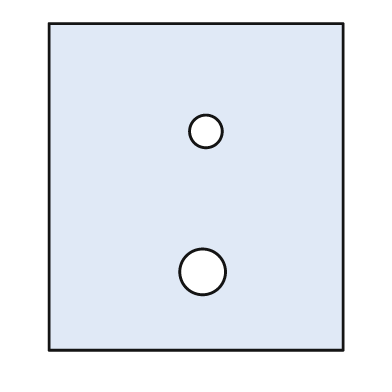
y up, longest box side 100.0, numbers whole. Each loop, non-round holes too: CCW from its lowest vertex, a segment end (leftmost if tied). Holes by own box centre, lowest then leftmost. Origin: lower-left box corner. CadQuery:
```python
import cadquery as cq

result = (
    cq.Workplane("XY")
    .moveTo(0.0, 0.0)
    .lineTo(90.0, 0.0)
    .lineTo(90.0, 100.0)
    .lineTo(0.0, 100.0)
    .close()
    .moveTo(47.0, 24.0)
    .circle(7.0)
    .moveTo(48.0, 67.0)
    .circle(5.0)
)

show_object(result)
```